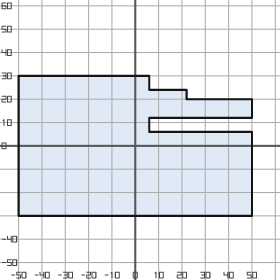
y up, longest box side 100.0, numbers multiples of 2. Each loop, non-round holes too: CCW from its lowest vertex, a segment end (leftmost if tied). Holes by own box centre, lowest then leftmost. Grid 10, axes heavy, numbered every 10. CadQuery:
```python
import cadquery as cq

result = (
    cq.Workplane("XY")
    .moveTo(-50.0, -30.0)
    .lineTo(50.0, -30.0)
    .lineTo(50.0, 6.0)
    .lineTo(6.0, 6.0)
    .lineTo(6.0, 12.0)
    .lineTo(50.0, 12.0)
    .lineTo(50.0, 20.0)
    .lineTo(22.0, 20.0)
    .lineTo(22.0, 24.0)
    .lineTo(6.0, 24.0)
    .lineTo(6.0, 30.0)
    .lineTo(-50.0, 30.0)
    .close()
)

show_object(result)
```